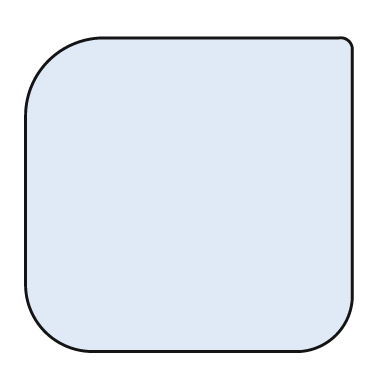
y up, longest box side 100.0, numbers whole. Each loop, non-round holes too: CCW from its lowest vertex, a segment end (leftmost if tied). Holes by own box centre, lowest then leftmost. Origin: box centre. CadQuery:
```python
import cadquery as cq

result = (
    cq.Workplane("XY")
    .moveTo(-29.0, -48.0)
    .lineTo(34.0, -48.0)
    .threePointArc((45.0, -43.0), (50.0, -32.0))
    .lineTo(50.0, 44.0)
    .threePointArc((49.0, 47.0), (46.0, 48.0))
    .lineTo(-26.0, 48.0)
    .threePointArc((-43.0, 41.0), (-50.0, 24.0))
    .lineTo(-50.0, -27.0)
    .threePointArc((-44.0, -42.0), (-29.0, -48.0))
    .close()
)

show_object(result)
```